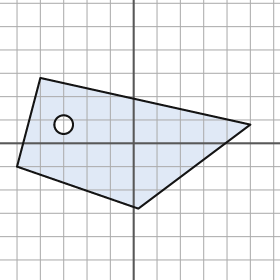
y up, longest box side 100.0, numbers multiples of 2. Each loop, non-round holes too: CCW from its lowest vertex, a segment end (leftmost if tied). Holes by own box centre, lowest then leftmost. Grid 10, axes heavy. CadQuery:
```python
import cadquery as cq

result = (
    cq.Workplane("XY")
    .moveTo(2.0, -28.0)
    .lineTo(50.0, 8.0)
    .lineTo(-40.0, 28.0)
    .lineTo(-50.0, -10.0)
    .close()
    .moveTo(-30.0, 8.0)
    .circle(4.0)
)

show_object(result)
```